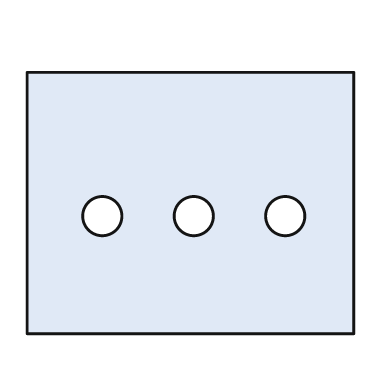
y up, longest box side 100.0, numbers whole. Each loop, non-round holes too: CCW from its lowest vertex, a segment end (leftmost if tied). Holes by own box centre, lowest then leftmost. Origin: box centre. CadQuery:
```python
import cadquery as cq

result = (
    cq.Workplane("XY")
    .moveTo(-50.0, -40.0)
    .lineTo(50.0, -40.0)
    .lineTo(50.0, 40.0)
    .lineTo(-50.0, 40.0)
    .close()
    .moveTo(-27.0, -4.0)
    .circle(6.0)
    .moveTo(1.0, -4.0)
    .circle(6.0)
    .moveTo(29.0, -4.0)
    .circle(6.0)
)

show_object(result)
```